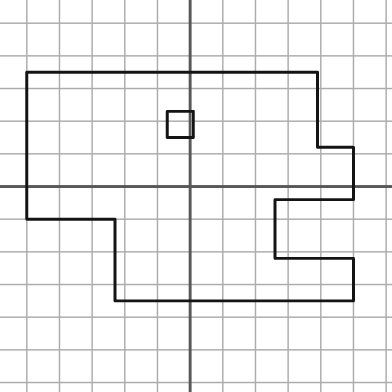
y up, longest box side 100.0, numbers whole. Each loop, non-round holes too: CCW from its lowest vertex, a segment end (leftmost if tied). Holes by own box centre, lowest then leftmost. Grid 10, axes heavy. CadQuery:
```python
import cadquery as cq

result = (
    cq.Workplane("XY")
    .moveTo(-23.0, -35.0)
    .lineTo(50.0, -35.0)
    .lineTo(50.0, -22.0)
    .lineTo(26.0, -22.0)
    .lineTo(26.0, -4.0)
    .lineTo(50.0, -4.0)
    .lineTo(50.0, 12.0)
    .lineTo(39.0, 12.0)
    .lineTo(39.0, 35.0)
    .lineTo(-50.0, 35.0)
    .lineTo(-50.0, -10.0)
    .lineTo(-23.0, -10.0)
    .close()
    .moveTo(-7.0, 15.0)
    .lineTo(1.0, 15.0)
    .lineTo(1.0, 23.0)
    .lineTo(-7.0, 23.0)
    .close()
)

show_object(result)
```